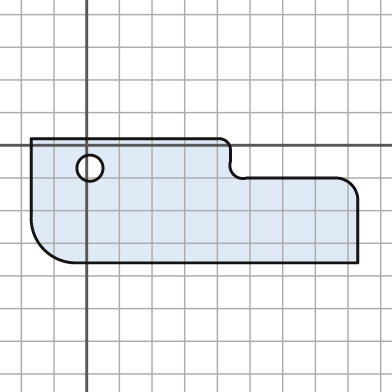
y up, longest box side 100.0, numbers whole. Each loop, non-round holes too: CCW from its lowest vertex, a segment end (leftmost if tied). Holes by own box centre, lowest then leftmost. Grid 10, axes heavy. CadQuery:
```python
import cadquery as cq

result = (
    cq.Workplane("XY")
    .moveTo(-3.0, -36.0)
    .lineTo(83.0, -36.0)
    .lineTo(83.0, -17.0)
    .threePointArc((81.0, -12.0), (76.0, -10.0))
    .lineTo(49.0, -10.0)
    .threePointArc((45.0, -9.0), (44.0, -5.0))
    .lineTo(44.0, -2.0)
    .threePointArc((43.0, 1.0), (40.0, 2.0))
    .lineTo(-17.0, 2.0)
    .lineTo(-17.0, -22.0)
    .threePointArc((-13.0, -32.0), (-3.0, -36.0))
    .close()
    .moveTo(1.0, -7.0)
    .circle(4.0)
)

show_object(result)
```